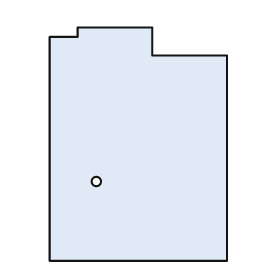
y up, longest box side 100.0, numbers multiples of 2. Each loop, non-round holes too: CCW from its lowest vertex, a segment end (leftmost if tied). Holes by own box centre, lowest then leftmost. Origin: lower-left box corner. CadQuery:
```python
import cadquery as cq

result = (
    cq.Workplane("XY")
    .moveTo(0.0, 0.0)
    .lineTo(76.0, 0.0)
    .lineTo(76.0, 88.0)
    .lineTo(44.0, 88.0)
    .lineTo(44.0, 100.0)
    .lineTo(12.0, 100.0)
    .lineTo(12.0, 96.0)
    .lineTo(0.0, 96.0)
    .close()
    .moveTo(20.0, 34.0)
    .circle(2.0)
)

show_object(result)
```